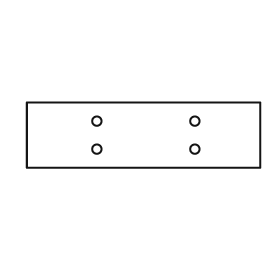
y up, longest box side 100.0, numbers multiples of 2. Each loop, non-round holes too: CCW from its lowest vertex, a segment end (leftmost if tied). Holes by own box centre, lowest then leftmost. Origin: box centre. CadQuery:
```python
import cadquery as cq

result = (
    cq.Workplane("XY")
    .moveTo(-50.0, -14.0)
    .lineTo(50.0, -14.0)
    .lineTo(50.0, 14.0)
    .lineTo(-50.0, 14.0)
    .close()
    .moveTo(-20.0, -6.0)
    .circle(2.0)
    .moveTo(22.0, -6.0)
    .circle(2.0)
    .moveTo(-20.0, 6.0)
    .circle(2.0)
    .moveTo(22.0, 6.0)
    .circle(2.0)
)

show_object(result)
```